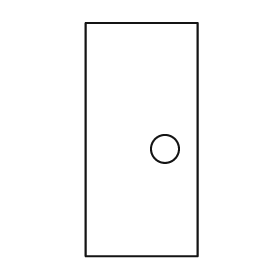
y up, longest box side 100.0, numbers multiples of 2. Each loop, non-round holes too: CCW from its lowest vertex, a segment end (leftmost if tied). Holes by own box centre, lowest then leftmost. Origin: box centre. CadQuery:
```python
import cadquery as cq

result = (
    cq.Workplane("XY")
    .moveTo(-24.0, -50.0)
    .lineTo(24.0, -50.0)
    .lineTo(24.0, 50.0)
    .lineTo(-24.0, 50.0)
    .close()
    .moveTo(10.0, -4.0)
    .circle(6.0)
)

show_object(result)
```